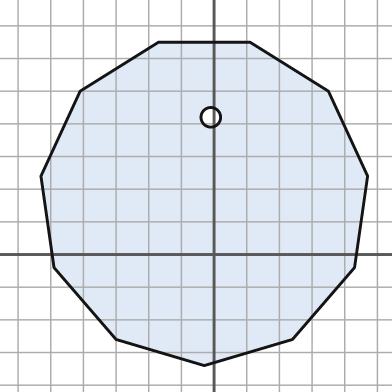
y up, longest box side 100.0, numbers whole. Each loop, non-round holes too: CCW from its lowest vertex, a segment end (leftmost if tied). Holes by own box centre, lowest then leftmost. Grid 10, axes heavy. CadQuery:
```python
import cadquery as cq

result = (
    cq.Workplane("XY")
    .moveTo(-3.0, -34.0)
    .lineTo(24.0, -26.0)
    .lineTo(43.0, -4.0)
    .lineTo(47.0, 24.0)
    .lineTo(35.0, 50.0)
    .lineTo(11.0, 65.0)
    .lineTo(-17.0, 65.0)
    .lineTo(-41.0, 50.0)
    .lineTo(-53.0, 24.0)
    .lineTo(-49.0, -4.0)
    .lineTo(-30.0, -26.0)
    .close()
    .moveTo(-1.0, 42.0)
    .circle(3.0)
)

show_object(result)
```